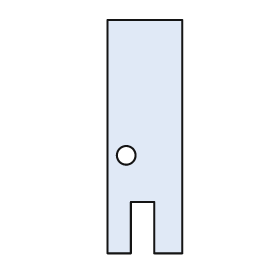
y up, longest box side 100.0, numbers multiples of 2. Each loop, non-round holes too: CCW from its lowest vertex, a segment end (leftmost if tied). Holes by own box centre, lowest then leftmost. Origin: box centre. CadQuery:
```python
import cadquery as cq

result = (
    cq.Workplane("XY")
    .moveTo(-16.0, -50.0)
    .lineTo(-6.0, -50.0)
    .lineTo(-6.0, -28.0)
    .lineTo(4.0, -28.0)
    .lineTo(4.0, -50.0)
    .lineTo(16.0, -50.0)
    .lineTo(16.0, 50.0)
    .lineTo(-16.0, 50.0)
    .close()
    .moveTo(-8.0, -8.0)
    .circle(4.0)
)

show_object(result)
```